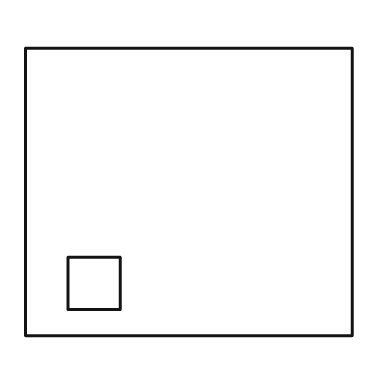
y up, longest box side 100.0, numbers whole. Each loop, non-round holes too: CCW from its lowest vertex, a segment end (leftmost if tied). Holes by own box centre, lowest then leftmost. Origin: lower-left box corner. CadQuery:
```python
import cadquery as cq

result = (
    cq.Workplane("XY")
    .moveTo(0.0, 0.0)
    .lineTo(100.0, 0.0)
    .lineTo(100.0, 88.0)
    .lineTo(0.0, 88.0)
    .close()
    .moveTo(13.0, 8.0)
    .lineTo(29.0, 8.0)
    .lineTo(29.0, 24.0)
    .lineTo(13.0, 24.0)
    .close()
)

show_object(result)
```